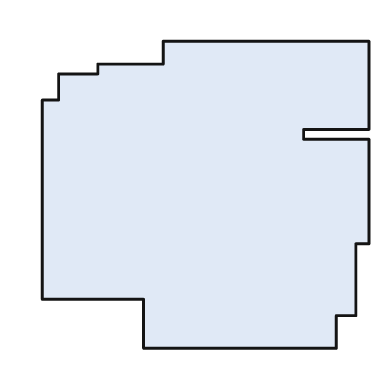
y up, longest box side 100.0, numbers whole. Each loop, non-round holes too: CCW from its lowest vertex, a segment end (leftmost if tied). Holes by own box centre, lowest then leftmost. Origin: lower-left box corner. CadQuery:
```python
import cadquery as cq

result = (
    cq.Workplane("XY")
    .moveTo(31.0, 0.0)
    .lineTo(90.0, 0.0)
    .lineTo(90.0, 10.0)
    .lineTo(96.0, 10.0)
    .lineTo(96.0, 32.0)
    .lineTo(100.0, 32.0)
    .lineTo(100.0, 64.0)
    .lineTo(80.0, 64.0)
    .lineTo(80.0, 67.0)
    .lineTo(100.0, 67.0)
    .lineTo(100.0, 94.0)
    .lineTo(37.0, 94.0)
    .lineTo(37.0, 87.0)
    .lineTo(17.0, 87.0)
    .lineTo(17.0, 84.0)
    .lineTo(5.0, 84.0)
    .lineTo(5.0, 76.0)
    .lineTo(0.0, 76.0)
    .lineTo(0.0, 15.0)
    .lineTo(31.0, 15.0)
    .close()
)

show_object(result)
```